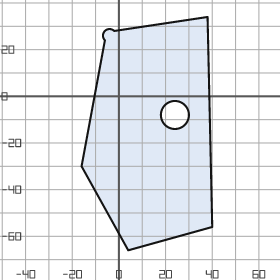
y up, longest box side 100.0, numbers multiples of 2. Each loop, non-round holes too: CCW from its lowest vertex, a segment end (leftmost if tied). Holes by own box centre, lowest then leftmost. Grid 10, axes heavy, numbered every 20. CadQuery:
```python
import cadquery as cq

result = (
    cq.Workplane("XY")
    .moveTo(4.0, -66.0)
    .lineTo(40.0, -56.0)
    .lineTo(38.0, 34.0)
    .lineTo(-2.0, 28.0)
    .threePointArc((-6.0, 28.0), (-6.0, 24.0))
    .lineTo(-16.0, -30.0)
    .close()
    .moveTo(24.0, -8.0)
    .circle(6.0)
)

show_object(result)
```